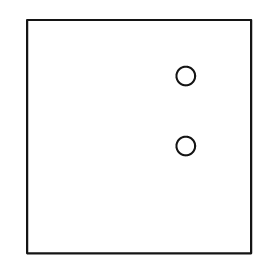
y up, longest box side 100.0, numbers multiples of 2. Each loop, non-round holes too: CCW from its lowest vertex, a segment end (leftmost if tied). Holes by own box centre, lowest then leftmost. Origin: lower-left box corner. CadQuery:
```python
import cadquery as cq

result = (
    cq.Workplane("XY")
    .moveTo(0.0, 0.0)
    .lineTo(96.0, 0.0)
    .lineTo(96.0, 100.0)
    .lineTo(0.0, 100.0)
    .close()
    .moveTo(68.0, 46.0)
    .circle(4.0)
    .moveTo(68.0, 76.0)
    .circle(4.0)
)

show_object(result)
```